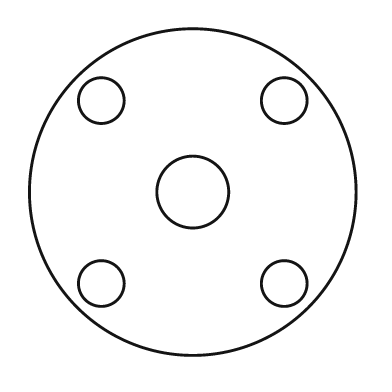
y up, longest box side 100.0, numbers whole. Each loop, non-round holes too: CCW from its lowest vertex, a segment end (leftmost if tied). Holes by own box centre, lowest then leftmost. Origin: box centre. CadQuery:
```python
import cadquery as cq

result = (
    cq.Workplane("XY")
    .moveTo(0.0, 0.0)
    .circle(50.0)
    .moveTo(-28.0, -28.0)
    .circle(7.0)
    .moveTo(28.0, -28.0)
    .circle(7.0)
    .moveTo(0.0, 0.0)
    .circle(11.0)
    .moveTo(-28.0, 28.0)
    .circle(7.0)
    .moveTo(28.0, 28.0)
    .circle(7.0)
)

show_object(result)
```